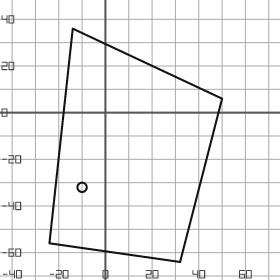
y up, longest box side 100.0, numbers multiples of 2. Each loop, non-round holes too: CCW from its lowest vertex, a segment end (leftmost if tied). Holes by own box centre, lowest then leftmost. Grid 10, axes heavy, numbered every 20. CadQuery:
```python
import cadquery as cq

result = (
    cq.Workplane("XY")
    .moveTo(32.0, -64.0)
    .lineTo(50.0, 6.0)
    .lineTo(-14.0, 36.0)
    .lineTo(-24.0, -56.0)
    .close()
    .moveTo(-10.0, -32.0)
    .circle(2.0)
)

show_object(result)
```